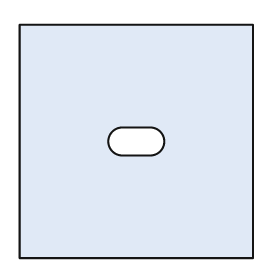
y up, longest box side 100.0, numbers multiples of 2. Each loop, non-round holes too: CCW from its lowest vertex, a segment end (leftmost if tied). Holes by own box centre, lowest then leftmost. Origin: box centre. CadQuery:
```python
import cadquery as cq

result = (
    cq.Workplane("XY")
    .moveTo(-50.0, -50.0)
    .lineTo(50.0, -50.0)
    .lineTo(50.0, 50.0)
    .lineTo(-50.0, 50.0)
    .close()
    .moveTo(-6.0, -6.0)
    .lineTo(6.0, -6.0)
    .threePointArc((12.0, 0.0), (6.0, 6.0))
    .lineTo(-6.0, 6.0)
    .threePointArc((-12.0, 0.0), (-6.0, -6.0))
    .close()
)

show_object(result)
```